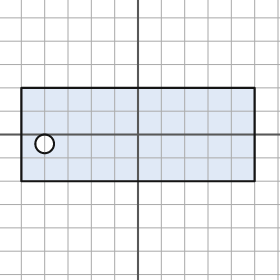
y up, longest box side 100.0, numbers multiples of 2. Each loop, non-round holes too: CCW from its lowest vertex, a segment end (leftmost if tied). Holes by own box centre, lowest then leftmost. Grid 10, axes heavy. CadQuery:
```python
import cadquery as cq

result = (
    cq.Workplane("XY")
    .moveTo(-50.0, -20.0)
    .lineTo(50.0, -20.0)
    .lineTo(50.0, 20.0)
    .lineTo(-50.0, 20.0)
    .close()
    .moveTo(-40.0, -4.0)
    .circle(4.0)
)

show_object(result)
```